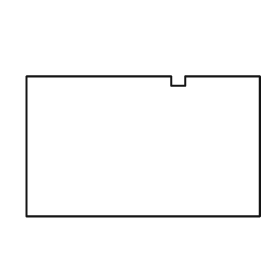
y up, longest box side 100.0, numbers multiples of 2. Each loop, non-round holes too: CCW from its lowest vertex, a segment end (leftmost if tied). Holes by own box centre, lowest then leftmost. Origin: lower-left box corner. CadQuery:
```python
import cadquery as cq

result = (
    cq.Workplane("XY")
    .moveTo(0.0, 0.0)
    .lineTo(100.0, 0.0)
    .lineTo(100.0, 60.0)
    .lineTo(68.0, 60.0)
    .lineTo(68.0, 56.0)
    .lineTo(62.0, 56.0)
    .lineTo(62.0, 60.0)
    .lineTo(0.0, 60.0)
    .close()
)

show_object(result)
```